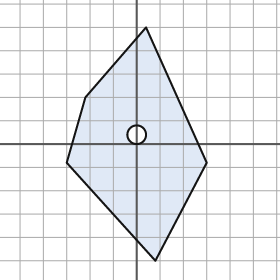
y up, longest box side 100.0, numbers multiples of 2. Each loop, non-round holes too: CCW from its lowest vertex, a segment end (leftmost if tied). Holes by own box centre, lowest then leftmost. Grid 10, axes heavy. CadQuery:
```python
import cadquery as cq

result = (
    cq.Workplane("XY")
    .moveTo(8.0, -50.0)
    .lineTo(30.0, -8.0)
    .lineTo(4.0, 50.0)
    .lineTo(-22.0, 20.0)
    .lineTo(-30.0, -8.0)
    .close()
    .moveTo(0.0, 4.0)
    .circle(4.0)
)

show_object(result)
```